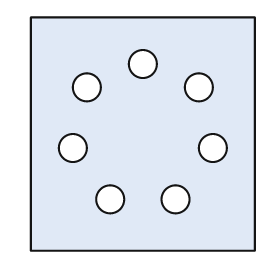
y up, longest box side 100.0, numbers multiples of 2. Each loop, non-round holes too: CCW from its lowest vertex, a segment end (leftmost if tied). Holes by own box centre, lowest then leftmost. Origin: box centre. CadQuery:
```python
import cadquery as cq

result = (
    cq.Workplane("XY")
    .moveTo(-48.0, -50.0)
    .lineTo(48.0, -50.0)
    .lineTo(48.0, 50.0)
    .lineTo(-48.0, 50.0)
    .close()
    .moveTo(-14.0, -28.0)
    .circle(6.0)
    .moveTo(14.0, -28.0)
    .circle(6.0)
    .moveTo(-30.0, -6.0)
    .circle(6.0)
    .moveTo(30.0, -6.0)
    .circle(6.0)
    .moveTo(-24.0, 20.0)
    .circle(6.0)
    .moveTo(24.0, 20.0)
    .circle(6.0)
    .moveTo(0.0, 30.0)
    .circle(6.0)
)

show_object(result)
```